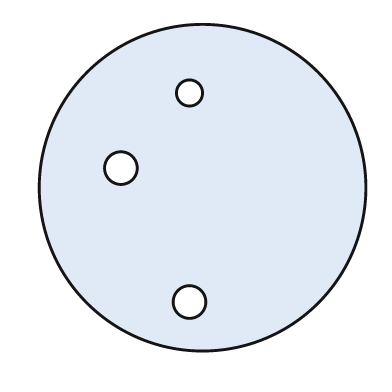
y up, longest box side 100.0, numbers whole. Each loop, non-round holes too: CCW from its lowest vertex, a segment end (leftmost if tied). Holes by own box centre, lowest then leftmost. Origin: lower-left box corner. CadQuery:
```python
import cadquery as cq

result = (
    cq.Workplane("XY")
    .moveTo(50.0, 50.0)
    .circle(50.0)
    .moveTo(46.0, 15.0)
    .circle(5.0)
    .moveTo(25.0, 56.0)
    .circle(5.0)
    .moveTo(46.0, 79.0)
    .circle(4.0)
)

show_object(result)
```